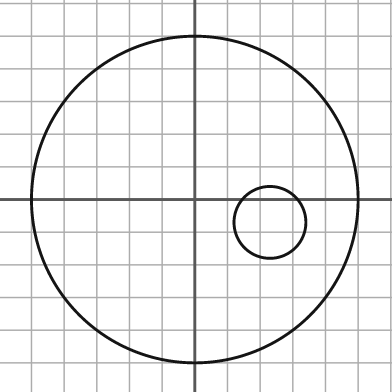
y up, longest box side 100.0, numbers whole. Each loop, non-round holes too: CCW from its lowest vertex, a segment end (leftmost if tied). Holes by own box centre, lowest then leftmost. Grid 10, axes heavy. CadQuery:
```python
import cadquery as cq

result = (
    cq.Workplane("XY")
    .moveTo(0.0, 0.0)
    .circle(50.0)
    .moveTo(23.0, -7.0)
    .circle(11.0)
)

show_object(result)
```